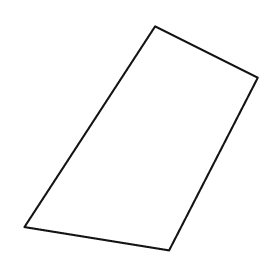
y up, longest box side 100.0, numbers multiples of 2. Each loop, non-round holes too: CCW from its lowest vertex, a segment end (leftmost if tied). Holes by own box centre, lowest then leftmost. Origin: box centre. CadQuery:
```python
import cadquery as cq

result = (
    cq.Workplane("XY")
    .moveTo(12.0, -48.0)
    .lineTo(50.0, 26.0)
    .lineTo(6.0, 48.0)
    .lineTo(-50.0, -38.0)
    .close()
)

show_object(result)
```